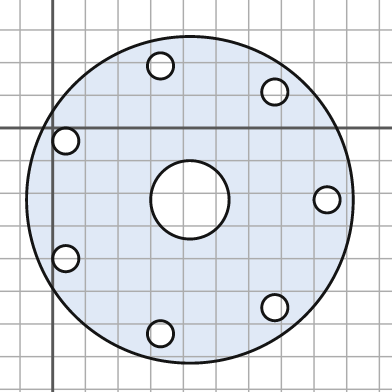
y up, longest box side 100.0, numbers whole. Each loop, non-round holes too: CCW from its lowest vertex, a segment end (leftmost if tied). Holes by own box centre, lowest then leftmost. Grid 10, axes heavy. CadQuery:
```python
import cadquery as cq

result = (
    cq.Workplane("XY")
    .moveTo(42.0, -22.0)
    .circle(50.0)
    .moveTo(33.0, -63.0)
    .circle(4.0)
    .moveTo(68.0, -55.0)
    .circle(4.0)
    .moveTo(4.0, -40.0)
    .circle(4.0)
    .moveTo(42.0, -22.0)
    .circle(12.0)
    .moveTo(84.0, -22.0)
    .circle(4.0)
    .moveTo(4.0, -4.0)
    .circle(4.0)
    .moveTo(68.0, 11.0)
    .circle(4.0)
    .moveTo(33.0, 19.0)
    .circle(4.0)
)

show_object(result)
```